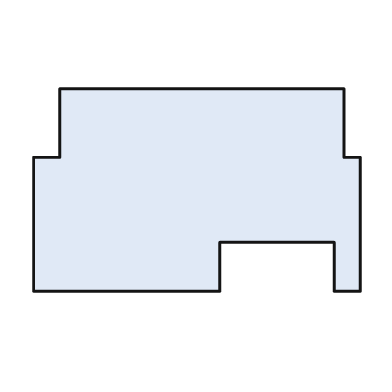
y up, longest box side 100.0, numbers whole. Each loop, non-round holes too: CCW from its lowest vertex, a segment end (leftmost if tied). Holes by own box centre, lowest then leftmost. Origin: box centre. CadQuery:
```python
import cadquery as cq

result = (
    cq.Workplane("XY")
    .moveTo(-50.0, -31.0)
    .lineTo(7.0, -31.0)
    .lineTo(7.0, -16.0)
    .lineTo(42.0, -16.0)
    .lineTo(42.0, -31.0)
    .lineTo(50.0, -31.0)
    .lineTo(50.0, 10.0)
    .lineTo(45.0, 10.0)
    .lineTo(45.0, 31.0)
    .lineTo(-42.0, 31.0)
    .lineTo(-42.0, 10.0)
    .lineTo(-50.0, 10.0)
    .close()
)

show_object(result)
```